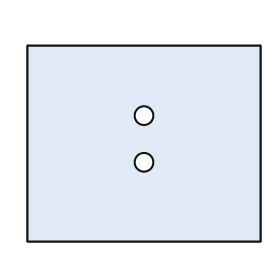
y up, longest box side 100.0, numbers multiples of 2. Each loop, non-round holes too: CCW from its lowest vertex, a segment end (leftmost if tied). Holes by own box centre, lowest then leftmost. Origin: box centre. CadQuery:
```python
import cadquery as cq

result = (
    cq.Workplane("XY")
    .moveTo(-50.0, -42.0)
    .lineTo(50.0, -42.0)
    .lineTo(50.0, 42.0)
    .lineTo(-50.0, 42.0)
    .close()
    .moveTo(0.0, -8.0)
    .circle(4.0)
    .moveTo(0.0, 12.0)
    .circle(4.0)
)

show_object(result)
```